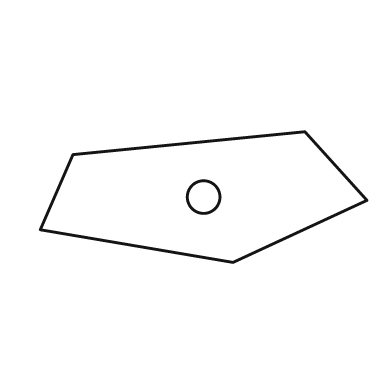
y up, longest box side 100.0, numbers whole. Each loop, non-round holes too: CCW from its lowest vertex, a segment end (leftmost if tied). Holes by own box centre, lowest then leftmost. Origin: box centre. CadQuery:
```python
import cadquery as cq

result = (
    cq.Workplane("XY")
    .moveTo(9.0, -20.0)
    .lineTo(50.0, -1.0)
    .lineTo(31.0, 20.0)
    .lineTo(-40.0, 13.0)
    .lineTo(-50.0, -10.0)
    .close()
    .moveTo(0.0, 0.0)
    .circle(5.0)
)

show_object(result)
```